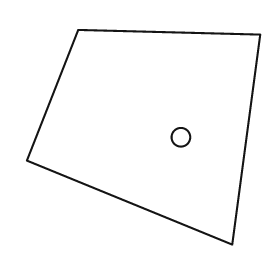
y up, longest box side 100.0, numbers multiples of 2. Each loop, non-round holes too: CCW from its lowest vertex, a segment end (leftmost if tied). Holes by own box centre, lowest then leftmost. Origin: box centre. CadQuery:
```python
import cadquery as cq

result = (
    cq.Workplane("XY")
    .moveTo(38.0, -46.0)
    .lineTo(50.0, 44.0)
    .lineTo(-28.0, 46.0)
    .lineTo(-50.0, -10.0)
    .close()
    .moveTo(16.0, 0.0)
    .circle(4.0)
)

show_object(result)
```